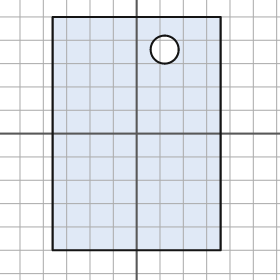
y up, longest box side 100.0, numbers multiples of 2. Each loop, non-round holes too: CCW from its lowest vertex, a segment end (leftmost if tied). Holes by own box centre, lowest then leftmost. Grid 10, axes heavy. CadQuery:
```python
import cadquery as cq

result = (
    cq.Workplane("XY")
    .moveTo(-36.0, -50.0)
    .lineTo(36.0, -50.0)
    .lineTo(36.0, 50.0)
    .lineTo(-36.0, 50.0)
    .close()
    .moveTo(12.0, 36.0)
    .circle(6.0)
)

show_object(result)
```